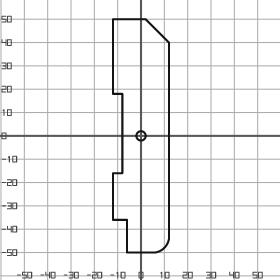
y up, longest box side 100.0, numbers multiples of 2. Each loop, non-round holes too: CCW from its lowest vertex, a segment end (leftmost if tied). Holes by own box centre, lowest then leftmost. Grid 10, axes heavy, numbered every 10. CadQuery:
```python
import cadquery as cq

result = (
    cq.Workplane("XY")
    .moveTo(-6.0, -50.0)
    .lineTo(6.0, -50.0)
    .threePointArc((10.0, -48.0), (12.0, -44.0))
    .lineTo(12.0, 40.0)
    .lineTo(2.0, 50.0)
    .lineTo(-12.0, 50.0)
    .lineTo(-12.0, 18.0)
    .lineTo(-8.0, 18.0)
    .lineTo(-8.0, -16.0)
    .lineTo(-12.0, -16.0)
    .lineTo(-12.0, -36.0)
    .lineTo(-6.0, -36.0)
    .close()
    .moveTo(0.0, 0.0)
    .circle(2.0)
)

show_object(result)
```